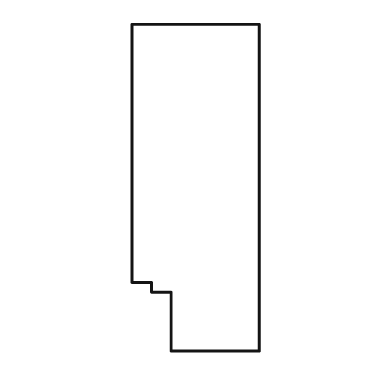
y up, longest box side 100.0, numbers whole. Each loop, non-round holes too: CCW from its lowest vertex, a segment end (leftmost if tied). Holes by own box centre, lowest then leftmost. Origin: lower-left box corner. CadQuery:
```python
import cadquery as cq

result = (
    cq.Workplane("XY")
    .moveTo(12.0, 0.0)
    .lineTo(39.0, 0.0)
    .lineTo(39.0, 100.0)
    .lineTo(0.0, 100.0)
    .lineTo(0.0, 21.0)
    .lineTo(6.0, 21.0)
    .lineTo(6.0, 18.0)
    .lineTo(12.0, 18.0)
    .close()
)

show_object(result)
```